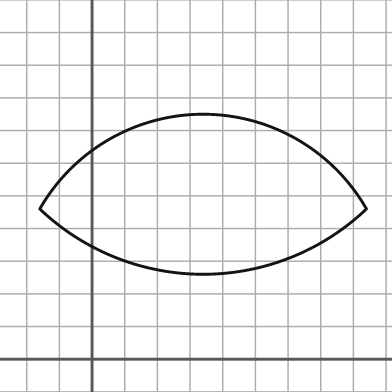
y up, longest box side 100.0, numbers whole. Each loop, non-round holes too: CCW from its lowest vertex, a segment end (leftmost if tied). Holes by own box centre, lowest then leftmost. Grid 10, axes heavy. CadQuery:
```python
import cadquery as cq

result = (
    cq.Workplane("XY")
    .moveTo(-16.0, 46.0)
    .threePointArc((34.0, 26.0), (84.0, 46.0))
    .threePointArc((34.0, 75.0), (-16.0, 46.0))
    .close()
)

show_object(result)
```